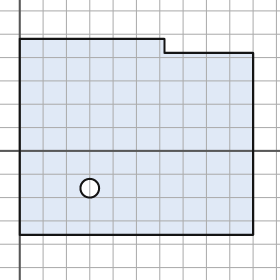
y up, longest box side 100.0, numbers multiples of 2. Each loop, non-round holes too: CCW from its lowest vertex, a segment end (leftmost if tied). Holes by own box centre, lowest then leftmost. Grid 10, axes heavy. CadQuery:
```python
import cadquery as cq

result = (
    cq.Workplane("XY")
    .moveTo(0.0, -36.0)
    .lineTo(100.0, -36.0)
    .lineTo(100.0, 42.0)
    .lineTo(62.0, 42.0)
    .lineTo(62.0, 48.0)
    .lineTo(0.0, 48.0)
    .close()
    .moveTo(30.0, -16.0)
    .circle(4.0)
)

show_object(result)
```